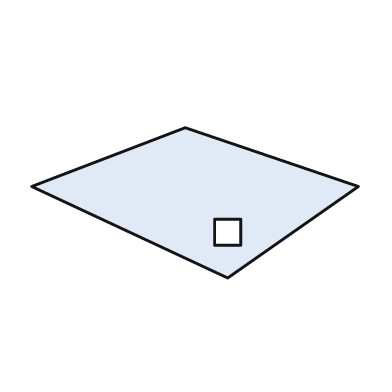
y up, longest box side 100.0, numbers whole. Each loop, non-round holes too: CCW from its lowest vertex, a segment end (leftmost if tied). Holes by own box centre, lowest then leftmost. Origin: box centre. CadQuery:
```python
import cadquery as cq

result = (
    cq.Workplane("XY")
    .moveTo(10.0, -23.0)
    .lineTo(50.0, 5.0)
    .lineTo(-3.0, 23.0)
    .lineTo(-50.0, 5.0)
    .close()
    .moveTo(6.0, -13.0)
    .lineTo(14.0, -13.0)
    .lineTo(14.0, -5.0)
    .lineTo(6.0, -5.0)
    .close()
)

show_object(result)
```